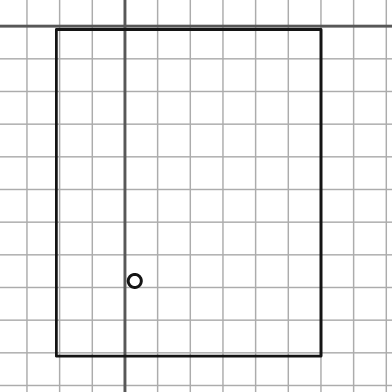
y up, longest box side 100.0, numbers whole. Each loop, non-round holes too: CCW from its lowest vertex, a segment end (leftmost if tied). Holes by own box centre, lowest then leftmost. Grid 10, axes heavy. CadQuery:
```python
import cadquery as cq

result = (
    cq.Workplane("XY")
    .moveTo(-21.0, -101.0)
    .lineTo(60.0, -101.0)
    .lineTo(60.0, -1.0)
    .lineTo(-21.0, -1.0)
    .close()
    .moveTo(3.0, -78.0)
    .circle(2.0)
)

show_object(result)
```